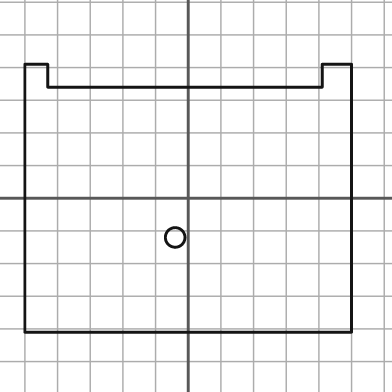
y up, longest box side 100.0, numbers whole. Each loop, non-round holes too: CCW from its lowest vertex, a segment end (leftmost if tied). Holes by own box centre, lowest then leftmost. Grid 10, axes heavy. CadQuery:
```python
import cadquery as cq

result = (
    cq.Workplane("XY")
    .moveTo(-50.0, -41.0)
    .lineTo(50.0, -41.0)
    .lineTo(50.0, 41.0)
    .lineTo(41.0, 41.0)
    .lineTo(41.0, 34.0)
    .lineTo(-43.0, 34.0)
    .lineTo(-43.0, 41.0)
    .lineTo(-50.0, 41.0)
    .close()
    .moveTo(-4.0, -12.0)
    .circle(3.0)
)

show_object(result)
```